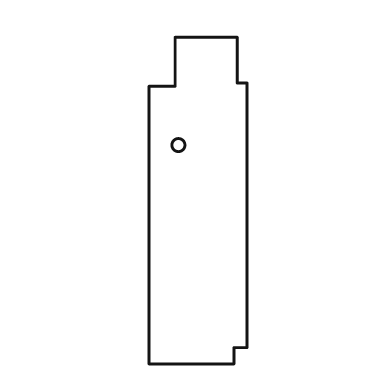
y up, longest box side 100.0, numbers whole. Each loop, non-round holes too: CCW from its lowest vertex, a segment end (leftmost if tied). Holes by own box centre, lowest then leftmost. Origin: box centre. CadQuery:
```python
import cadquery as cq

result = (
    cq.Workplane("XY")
    .moveTo(-15.0, -50.0)
    .lineTo(11.0, -50.0)
    .lineTo(11.0, -45.0)
    .lineTo(15.0, -45.0)
    .lineTo(15.0, 36.0)
    .lineTo(12.0, 36.0)
    .lineTo(12.0, 50.0)
    .lineTo(-7.0, 50.0)
    .lineTo(-7.0, 35.0)
    .lineTo(-15.0, 35.0)
    .close()
    .moveTo(-6.0, 17.0)
    .circle(2.0)
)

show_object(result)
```